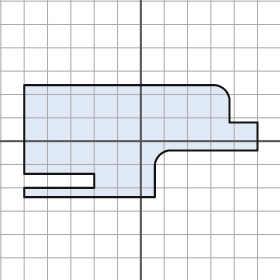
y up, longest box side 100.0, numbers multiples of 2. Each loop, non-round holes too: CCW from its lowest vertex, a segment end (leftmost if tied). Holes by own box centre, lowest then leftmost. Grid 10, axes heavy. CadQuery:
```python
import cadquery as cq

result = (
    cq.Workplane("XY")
    .moveTo(-50.0, -24.0)
    .lineTo(6.0, -24.0)
    .lineTo(6.0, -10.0)
    .threePointArc((8.0, -6.0), (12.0, -4.0))
    .lineTo(50.0, -4.0)
    .lineTo(50.0, 8.0)
    .lineTo(38.0, 8.0)
    .lineTo(38.0, 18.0)
    .threePointArc((36.0, 22.0), (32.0, 24.0))
    .lineTo(-50.0, 24.0)
    .lineTo(-50.0, -14.0)
    .lineTo(-20.0, -14.0)
    .lineTo(-20.0, -20.0)
    .lineTo(-50.0, -20.0)
    .close()
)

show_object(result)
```